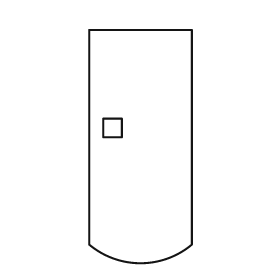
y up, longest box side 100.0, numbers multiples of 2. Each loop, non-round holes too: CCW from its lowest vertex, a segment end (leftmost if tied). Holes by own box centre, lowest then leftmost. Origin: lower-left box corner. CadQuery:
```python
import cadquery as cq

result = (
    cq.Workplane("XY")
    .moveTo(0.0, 8.0)
    .threePointArc((22.0, 0.0), (44.0, 8.0))
    .lineTo(44.0, 100.0)
    .lineTo(0.0, 100.0)
    .close()
    .moveTo(6.0, 54.0)
    .lineTo(14.0, 54.0)
    .lineTo(14.0, 62.0)
    .lineTo(6.0, 62.0)
    .close()
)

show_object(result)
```